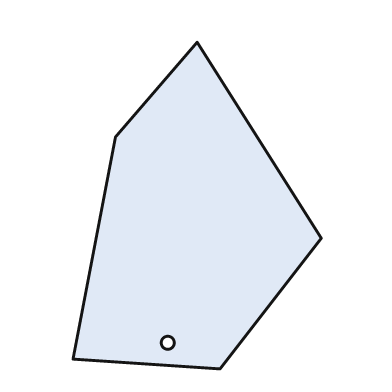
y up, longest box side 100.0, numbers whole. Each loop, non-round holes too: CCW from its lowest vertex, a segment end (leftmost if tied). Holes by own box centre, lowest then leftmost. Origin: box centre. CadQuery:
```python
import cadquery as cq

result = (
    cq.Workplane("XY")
    .moveTo(7.0, -50.0)
    .lineTo(38.0, -10.0)
    .lineTo(0.0, 50.0)
    .lineTo(-25.0, 21.0)
    .lineTo(-38.0, -47.0)
    .close()
    .moveTo(-9.0, -42.0)
    .circle(2.0)
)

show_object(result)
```